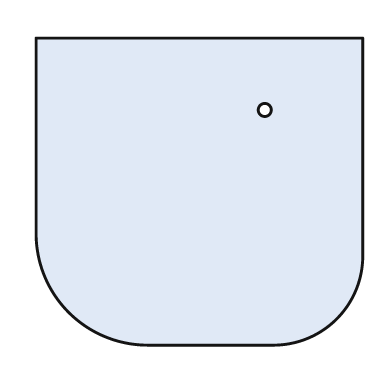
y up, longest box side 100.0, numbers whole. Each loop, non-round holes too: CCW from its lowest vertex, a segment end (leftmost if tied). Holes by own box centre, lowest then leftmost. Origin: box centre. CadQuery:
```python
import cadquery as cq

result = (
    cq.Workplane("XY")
    .moveTo(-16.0, -47.0)
    .lineTo(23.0, -47.0)
    .threePointArc((42.0, -39.0), (50.0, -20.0))
    .lineTo(50.0, 47.0)
    .lineTo(-50.0, 47.0)
    .lineTo(-50.0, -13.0)
    .threePointArc((-40.0, -37.0), (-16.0, -47.0))
    .close()
    .moveTo(20.0, 25.0)
    .circle(2.0)
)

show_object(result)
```